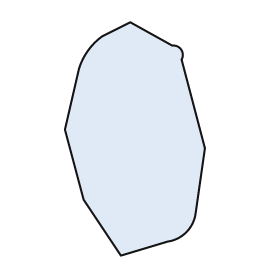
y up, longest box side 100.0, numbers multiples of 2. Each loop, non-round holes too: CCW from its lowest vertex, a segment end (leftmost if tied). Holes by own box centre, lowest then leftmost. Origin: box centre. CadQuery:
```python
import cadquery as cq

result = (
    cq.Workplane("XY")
    .moveTo(-6.0, -50.0)
    .lineTo(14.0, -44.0)
    .threePointArc((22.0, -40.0), (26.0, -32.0))
    .lineTo(30.0, -4.0)
    .lineTo(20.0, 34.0)
    .threePointArc((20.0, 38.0), (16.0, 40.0))
    .lineTo(-2.0, 50.0)
    .lineTo(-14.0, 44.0)
    .threePointArc((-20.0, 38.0), (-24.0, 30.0))
    .lineTo(-30.0, 4.0)
    .lineTo(-22.0, -26.0)
    .close()
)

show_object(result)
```